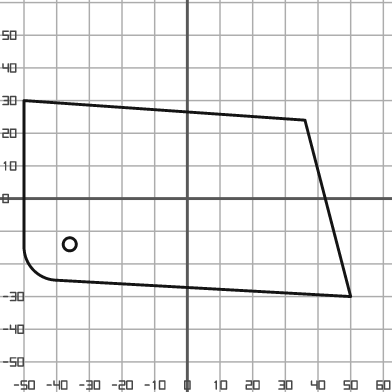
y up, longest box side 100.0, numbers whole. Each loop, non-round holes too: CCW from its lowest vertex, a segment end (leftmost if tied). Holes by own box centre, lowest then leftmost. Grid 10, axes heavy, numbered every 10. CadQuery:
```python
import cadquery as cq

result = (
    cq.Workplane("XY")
    .moveTo(50.0, -30.0)
    .lineTo(36.0, 24.0)
    .lineTo(-50.0, 30.0)
    .lineTo(-50.0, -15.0)
    .threePointArc((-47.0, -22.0), (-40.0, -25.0))
    .close()
    .moveTo(-36.0, -14.0)
    .circle(2.0)
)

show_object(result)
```